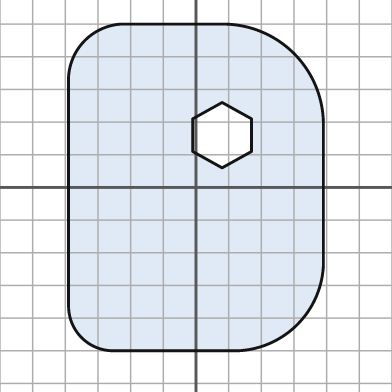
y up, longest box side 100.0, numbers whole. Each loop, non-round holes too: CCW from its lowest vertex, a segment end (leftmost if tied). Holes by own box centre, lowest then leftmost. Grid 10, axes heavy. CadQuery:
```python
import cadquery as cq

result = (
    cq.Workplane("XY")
    .moveTo(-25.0, -50.0)
    .lineTo(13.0, -50.0)
    .threePointArc((31.0, -42.0), (39.0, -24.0))
    .lineTo(39.0, 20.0)
    .threePointArc((30.0, 41.0), (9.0, 50.0))
    .lineTo(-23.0, 50.0)
    .threePointArc((-34.0, 45.0), (-39.0, 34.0))
    .lineTo(-39.0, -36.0)
    .threePointArc((-35.0, -46.0), (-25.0, -50.0))
    .close()
    .moveTo(8.0, 6.0)
    .lineTo(17.0, 11.0)
    .lineTo(17.0, 21.0)
    .lineTo(8.0, 26.0)
    .lineTo(-1.0, 21.0)
    .lineTo(-1.0, 11.0)
    .close()
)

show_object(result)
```